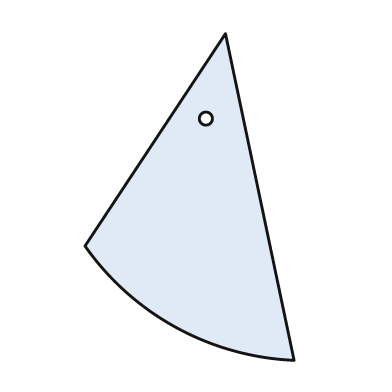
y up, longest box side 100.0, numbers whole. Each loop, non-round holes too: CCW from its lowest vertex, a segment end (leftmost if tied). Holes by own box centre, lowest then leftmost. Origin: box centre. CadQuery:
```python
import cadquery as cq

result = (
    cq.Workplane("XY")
    .moveTo(32.0, -50.0)
    .lineTo(11.0, 50.0)
    .lineTo(-32.0, -15.0)
    .threePointArc((-4.0, -40.0), (32.0, -50.0))
    .close()
    .moveTo(5.0, 24.0)
    .circle(2.0)
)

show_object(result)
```